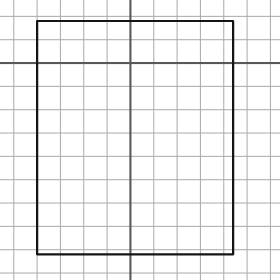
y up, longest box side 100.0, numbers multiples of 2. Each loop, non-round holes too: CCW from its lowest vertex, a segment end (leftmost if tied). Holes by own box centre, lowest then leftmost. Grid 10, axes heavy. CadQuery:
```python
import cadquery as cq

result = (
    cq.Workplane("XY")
    .moveTo(-40.0, -82.0)
    .lineTo(44.0, -82.0)
    .lineTo(44.0, 18.0)
    .lineTo(-40.0, 18.0)
    .close()
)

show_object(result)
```